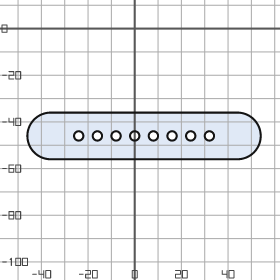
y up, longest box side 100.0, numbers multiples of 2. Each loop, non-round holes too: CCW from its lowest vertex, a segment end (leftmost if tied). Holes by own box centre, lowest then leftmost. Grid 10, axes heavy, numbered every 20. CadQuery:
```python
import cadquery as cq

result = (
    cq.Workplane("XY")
    .moveTo(-36.0, -56.0)
    .lineTo(44.0, -56.0)
    .threePointArc((54.0, -46.0), (44.0, -36.0))
    .lineTo(-36.0, -36.0)
    .threePointArc((-46.0, -46.0), (-36.0, -56.0))
    .close()
    .moveTo(-24.0, -46.0)
    .circle(2.0)
    .moveTo(-16.0, -46.0)
    .circle(2.0)
    .moveTo(-8.0, -46.0)
    .circle(2.0)
    .moveTo(0.0, -46.0)
    .circle(2.0)
    .moveTo(8.0, -46.0)
    .circle(2.0)
    .moveTo(16.0, -46.0)
    .circle(2.0)
    .moveTo(24.0, -46.0)
    .circle(2.0)
    .moveTo(32.0, -46.0)
    .circle(2.0)
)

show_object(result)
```